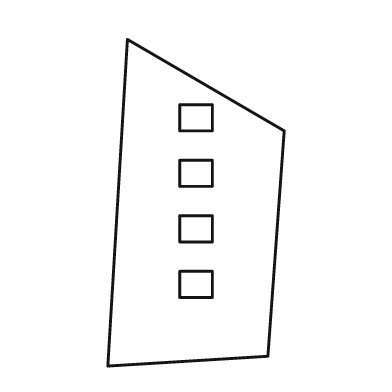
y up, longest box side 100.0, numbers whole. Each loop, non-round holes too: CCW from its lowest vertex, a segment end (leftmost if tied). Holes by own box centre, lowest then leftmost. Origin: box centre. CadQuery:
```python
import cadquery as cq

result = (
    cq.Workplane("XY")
    .moveTo(-27.0, -50.0)
    .lineTo(22.0, -47.0)
    .lineTo(27.0, 22.0)
    .lineTo(-21.0, 50.0)
    .close()
    .moveTo(-5.0, -29.0)
    .lineTo(5.0, -29.0)
    .lineTo(5.0, -21.0)
    .lineTo(-5.0, -21.0)
    .close()
    .moveTo(-5.0, -12.0)
    .lineTo(5.0, -12.0)
    .lineTo(5.0, -4.0)
    .lineTo(-5.0, -4.0)
    .close()
    .moveTo(-5.0, 5.0)
    .lineTo(5.0, 5.0)
    .lineTo(5.0, 13.0)
    .lineTo(-5.0, 13.0)
    .close()
    .moveTo(-5.0, 22.0)
    .lineTo(5.0, 22.0)
    .lineTo(5.0, 30.0)
    .lineTo(-5.0, 30.0)
    .close()
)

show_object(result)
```